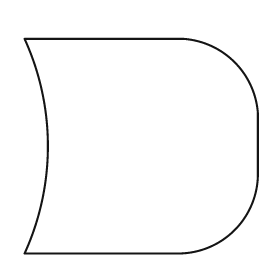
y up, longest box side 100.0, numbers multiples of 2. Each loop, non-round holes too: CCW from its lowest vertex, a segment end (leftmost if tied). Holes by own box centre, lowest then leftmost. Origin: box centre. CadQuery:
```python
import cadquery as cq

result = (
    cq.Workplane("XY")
    .moveTo(-50.0, -46.0)
    .lineTo(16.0, -46.0)
    .threePointArc((40.0, -36.0), (50.0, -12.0))
    .lineTo(50.0, 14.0)
    .threePointArc((40.0, 36.0), (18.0, 46.0))
    .lineTo(-50.0, 46.0)
    .threePointArc((-40.0, 0.0), (-50.0, -46.0))
    .close()
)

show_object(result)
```